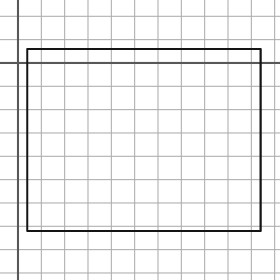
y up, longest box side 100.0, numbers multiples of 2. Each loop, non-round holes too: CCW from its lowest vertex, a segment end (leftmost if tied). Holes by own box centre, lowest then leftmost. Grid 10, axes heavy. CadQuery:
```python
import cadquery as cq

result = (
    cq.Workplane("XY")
    .moveTo(4.0, -72.0)
    .lineTo(104.0, -72.0)
    .lineTo(104.0, 6.0)
    .lineTo(4.0, 6.0)
    .close()
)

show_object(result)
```